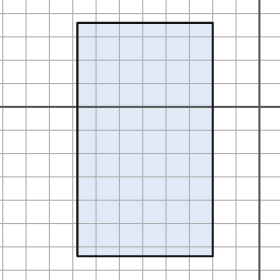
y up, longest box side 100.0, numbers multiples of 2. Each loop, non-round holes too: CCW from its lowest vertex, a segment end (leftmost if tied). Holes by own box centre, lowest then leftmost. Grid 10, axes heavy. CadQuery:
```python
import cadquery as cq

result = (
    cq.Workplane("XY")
    .moveTo(-78.0, -64.0)
    .lineTo(-20.0, -64.0)
    .lineTo(-20.0, 36.0)
    .lineTo(-78.0, 36.0)
    .close()
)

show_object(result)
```